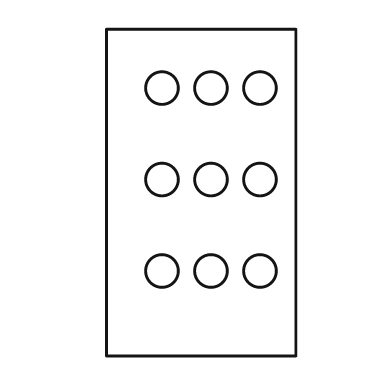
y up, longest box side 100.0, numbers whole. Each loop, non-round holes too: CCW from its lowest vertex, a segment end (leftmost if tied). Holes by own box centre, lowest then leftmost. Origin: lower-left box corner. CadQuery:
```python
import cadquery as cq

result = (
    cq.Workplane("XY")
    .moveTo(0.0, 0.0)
    .lineTo(58.0, 0.0)
    .lineTo(58.0, 100.0)
    .lineTo(0.0, 100.0)
    .close()
    .moveTo(17.0, 26.0)
    .circle(5.0)
    .moveTo(32.0, 26.0)
    .circle(5.0)
    .moveTo(47.0, 26.0)
    .circle(5.0)
    .moveTo(17.0, 54.0)
    .circle(5.0)
    .moveTo(32.0, 54.0)
    .circle(5.0)
    .moveTo(47.0, 54.0)
    .circle(5.0)
    .moveTo(17.0, 82.0)
    .circle(5.0)
    .moveTo(32.0, 82.0)
    .circle(5.0)
    .moveTo(47.0, 82.0)
    .circle(5.0)
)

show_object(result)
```